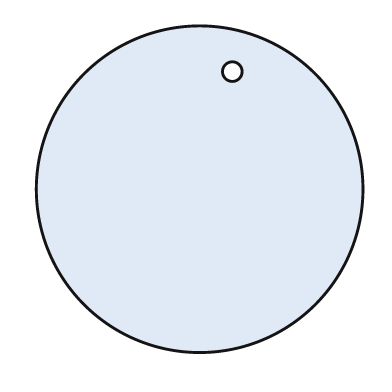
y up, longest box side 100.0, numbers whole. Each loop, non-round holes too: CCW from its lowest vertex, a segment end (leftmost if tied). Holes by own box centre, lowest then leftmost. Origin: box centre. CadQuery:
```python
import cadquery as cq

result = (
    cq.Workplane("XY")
    .moveTo(0.0, 0.0)
    .circle(50.0)
    .moveTo(10.0, 36.0)
    .circle(3.0)
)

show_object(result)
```